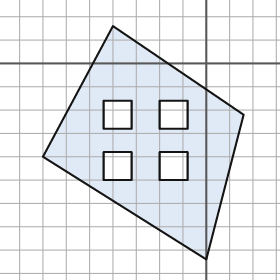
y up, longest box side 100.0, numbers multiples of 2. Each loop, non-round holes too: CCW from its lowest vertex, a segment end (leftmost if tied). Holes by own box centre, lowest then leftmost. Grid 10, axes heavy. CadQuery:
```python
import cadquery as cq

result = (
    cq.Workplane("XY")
    .moveTo(0.0, -84.0)
    .lineTo(16.0, -22.0)
    .lineTo(-40.0, 16.0)
    .lineTo(-70.0, -40.0)
    .close()
    .moveTo(-44.0, -50.0)
    .lineTo(-32.0, -50.0)
    .lineTo(-32.0, -38.0)
    .lineTo(-44.0, -38.0)
    .close()
    .moveTo(-20.0, -50.0)
    .lineTo(-8.0, -50.0)
    .lineTo(-8.0, -38.0)
    .lineTo(-20.0, -38.0)
    .close()
    .moveTo(-44.0, -28.0)
    .lineTo(-32.0, -28.0)
    .lineTo(-32.0, -16.0)
    .lineTo(-44.0, -16.0)
    .close()
    .moveTo(-20.0, -28.0)
    .lineTo(-8.0, -28.0)
    .lineTo(-8.0, -16.0)
    .lineTo(-20.0, -16.0)
    .close()
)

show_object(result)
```